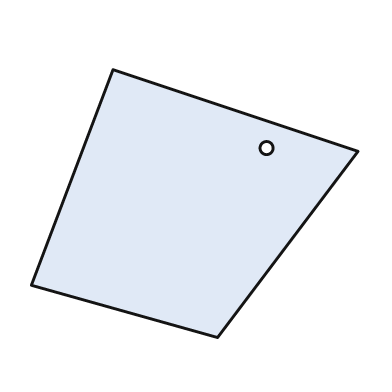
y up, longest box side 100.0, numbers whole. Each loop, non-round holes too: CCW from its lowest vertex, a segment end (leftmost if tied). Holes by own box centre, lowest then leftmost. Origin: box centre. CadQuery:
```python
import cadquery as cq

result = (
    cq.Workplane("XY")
    .moveTo(7.0, -41.0)
    .lineTo(50.0, 16.0)
    .lineTo(-25.0, 41.0)
    .lineTo(-50.0, -25.0)
    .close()
    .moveTo(22.0, 17.0)
    .circle(2.0)
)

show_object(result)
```